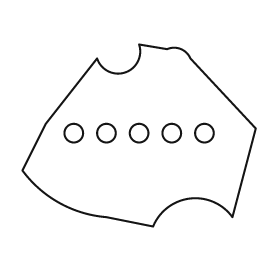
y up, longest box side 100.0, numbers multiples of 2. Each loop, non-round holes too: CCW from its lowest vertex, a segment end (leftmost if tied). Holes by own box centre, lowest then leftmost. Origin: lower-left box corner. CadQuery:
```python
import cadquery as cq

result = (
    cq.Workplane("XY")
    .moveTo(56.0, 0.0)
    .threePointArc((72.0, 12.0), (90.0, 4.0))
    .lineTo(100.0, 42.0)
    .lineTo(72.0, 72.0)
    .threePointArc((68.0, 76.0), (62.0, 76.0))
    .lineTo(50.0, 78.0)
    .threePointArc((44.0, 66.0), (32.0, 72.0))
    .lineTo(10.0, 44.0)
    .lineTo(0.0, 24.0)
    .threePointArc((16.0, 10.0), (36.0, 4.0))
    .close()
    .moveTo(22.0, 40.0)
    .circle(4.0)
    .moveTo(36.0, 40.0)
    .circle(4.0)
    .moveTo(50.0, 40.0)
    .circle(4.0)
    .moveTo(64.0, 40.0)
    .circle(4.0)
    .moveTo(78.0, 40.0)
    .circle(4.0)
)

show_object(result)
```